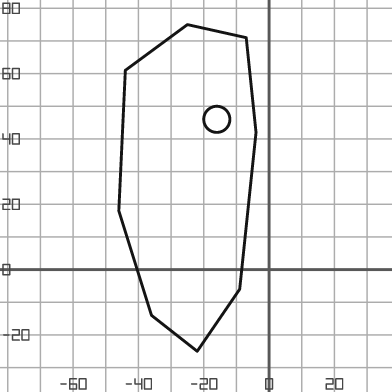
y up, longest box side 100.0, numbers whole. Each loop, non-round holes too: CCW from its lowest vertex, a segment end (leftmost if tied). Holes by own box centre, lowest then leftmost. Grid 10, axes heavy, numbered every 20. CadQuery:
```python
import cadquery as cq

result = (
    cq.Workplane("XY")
    .moveTo(-22.0, -25.0)
    .lineTo(-9.0, -6.0)
    .lineTo(-4.0, 42.0)
    .lineTo(-7.0, 71.0)
    .lineTo(-25.0, 75.0)
    .lineTo(-44.0, 61.0)
    .lineTo(-46.0, 18.0)
    .lineTo(-36.0, -14.0)
    .close()
    .moveTo(-16.0, 46.0)
    .circle(4.0)
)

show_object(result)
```